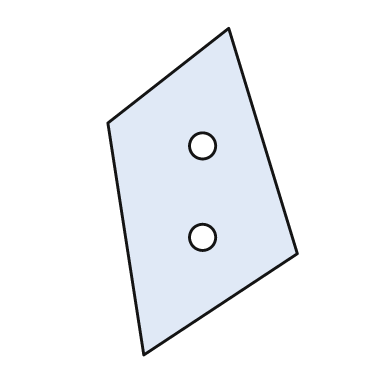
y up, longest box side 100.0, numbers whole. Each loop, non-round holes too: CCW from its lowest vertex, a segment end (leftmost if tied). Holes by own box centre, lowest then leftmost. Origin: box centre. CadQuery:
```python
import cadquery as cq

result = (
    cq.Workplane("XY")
    .moveTo(-18.0, -50.0)
    .lineTo(29.0, -19.0)
    .lineTo(8.0, 50.0)
    .lineTo(-29.0, 21.0)
    .close()
    .moveTo(0.0, -14.0)
    .circle(4.0)
    .moveTo(0.0, 14.0)
    .circle(4.0)
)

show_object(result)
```